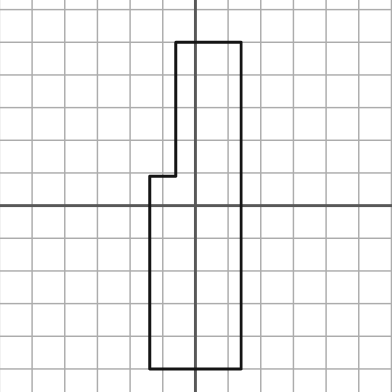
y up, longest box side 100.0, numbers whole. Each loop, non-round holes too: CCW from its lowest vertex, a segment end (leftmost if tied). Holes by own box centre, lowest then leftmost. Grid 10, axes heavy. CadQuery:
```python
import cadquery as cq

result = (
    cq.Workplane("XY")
    .moveTo(-14.0, -50.0)
    .lineTo(14.0, -50.0)
    .lineTo(14.0, 50.0)
    .lineTo(-6.0, 50.0)
    .lineTo(-6.0, 9.0)
    .lineTo(-14.0, 9.0)
    .close()
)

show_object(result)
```